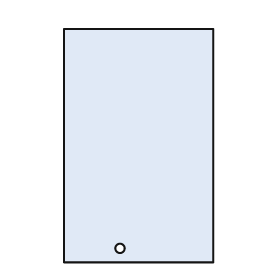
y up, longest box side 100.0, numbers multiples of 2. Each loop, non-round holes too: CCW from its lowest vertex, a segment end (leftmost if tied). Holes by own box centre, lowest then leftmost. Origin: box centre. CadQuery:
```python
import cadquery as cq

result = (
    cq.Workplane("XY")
    .moveTo(-32.0, -50.0)
    .lineTo(32.0, -50.0)
    .lineTo(32.0, 50.0)
    .lineTo(-32.0, 50.0)
    .close()
    .moveTo(-8.0, -44.0)
    .circle(2.0)
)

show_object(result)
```